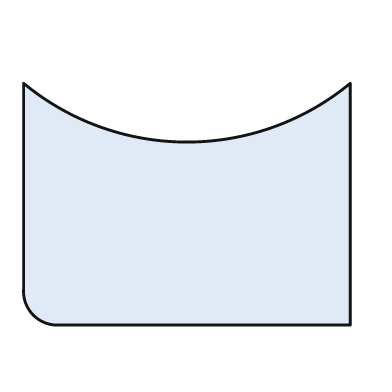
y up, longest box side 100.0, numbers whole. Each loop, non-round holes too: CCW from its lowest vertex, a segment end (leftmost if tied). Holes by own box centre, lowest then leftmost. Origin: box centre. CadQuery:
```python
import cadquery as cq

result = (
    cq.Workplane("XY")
    .moveTo(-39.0, -37.0)
    .lineTo(50.0, -37.0)
    .lineTo(50.0, 37.0)
    .threePointArc((0.0, 19.0), (-50.0, 37.0))
    .lineTo(-50.0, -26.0)
    .threePointArc((-47.0, -34.0), (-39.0, -37.0))
    .close()
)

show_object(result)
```